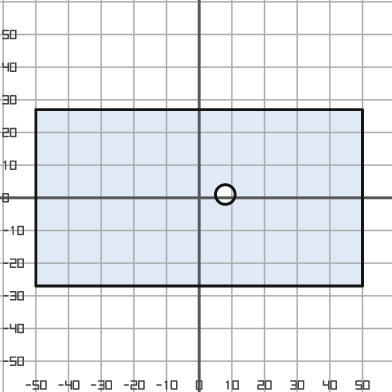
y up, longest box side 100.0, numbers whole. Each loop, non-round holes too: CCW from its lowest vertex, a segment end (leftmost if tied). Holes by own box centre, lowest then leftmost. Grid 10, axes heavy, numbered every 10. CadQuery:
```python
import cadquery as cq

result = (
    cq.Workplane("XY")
    .moveTo(-50.0, -27.0)
    .lineTo(50.0, -27.0)
    .lineTo(50.0, 27.0)
    .lineTo(-50.0, 27.0)
    .close()
    .moveTo(8.0, 1.0)
    .circle(3.0)
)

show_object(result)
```